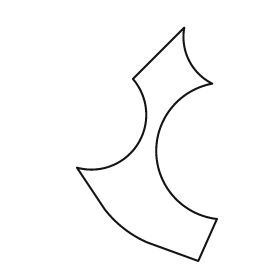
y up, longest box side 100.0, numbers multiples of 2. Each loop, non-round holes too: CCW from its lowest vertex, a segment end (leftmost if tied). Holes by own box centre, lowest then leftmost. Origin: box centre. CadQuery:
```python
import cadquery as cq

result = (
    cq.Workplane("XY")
    .moveTo(22.0, -50.0)
    .lineTo(30.0, -32.0)
    .threePointArc((4.0, -4.0), (28.0, 26.0))
    .threePointArc((18.0, 36.0), (16.0, 50.0))
    .lineTo(-6.0, 28.0)
    .threePointArc((-4.0, 0.0), (-30.0, -10.0))
    .lineTo(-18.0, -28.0)
    .threePointArc((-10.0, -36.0), (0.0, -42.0))
    .close()
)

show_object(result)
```